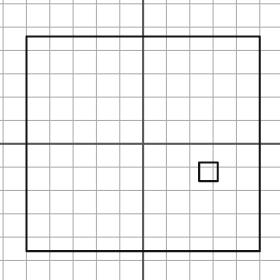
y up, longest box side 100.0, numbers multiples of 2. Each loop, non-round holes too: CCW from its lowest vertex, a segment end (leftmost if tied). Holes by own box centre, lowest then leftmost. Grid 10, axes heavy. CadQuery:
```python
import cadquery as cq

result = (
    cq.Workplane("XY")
    .moveTo(-50.0, -46.0)
    .lineTo(50.0, -46.0)
    .lineTo(50.0, 46.0)
    .lineTo(-50.0, 46.0)
    .close()
    .moveTo(24.0, -16.0)
    .lineTo(32.0, -16.0)
    .lineTo(32.0, -8.0)
    .lineTo(24.0, -8.0)
    .close()
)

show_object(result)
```